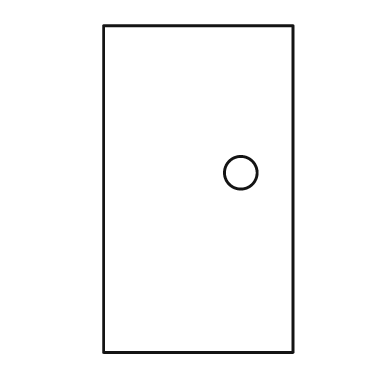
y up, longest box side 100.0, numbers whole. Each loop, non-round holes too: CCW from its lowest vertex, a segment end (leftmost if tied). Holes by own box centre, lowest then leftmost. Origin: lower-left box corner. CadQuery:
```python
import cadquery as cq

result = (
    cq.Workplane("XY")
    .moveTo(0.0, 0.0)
    .lineTo(58.0, 0.0)
    .lineTo(58.0, 100.0)
    .lineTo(0.0, 100.0)
    .close()
    .moveTo(42.0, 55.0)
    .circle(5.0)
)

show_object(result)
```